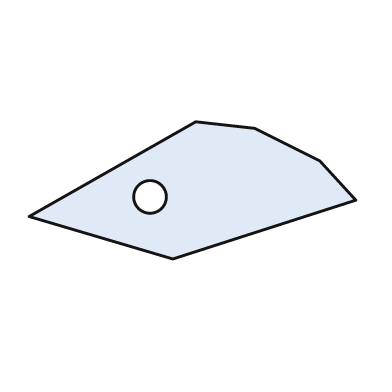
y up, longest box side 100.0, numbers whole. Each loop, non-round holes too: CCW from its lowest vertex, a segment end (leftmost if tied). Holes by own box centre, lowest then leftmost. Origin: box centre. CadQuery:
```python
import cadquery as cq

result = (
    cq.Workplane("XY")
    .moveTo(-6.0, -21.0)
    .lineTo(50.0, -3.0)
    .lineTo(39.0, 9.0)
    .lineTo(19.0, 19.0)
    .lineTo(1.0, 21.0)
    .lineTo(-50.0, -8.0)
    .close()
    .moveTo(-13.0, -2.0)
    .circle(5.0)
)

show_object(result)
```